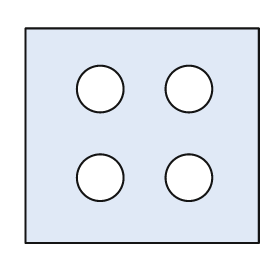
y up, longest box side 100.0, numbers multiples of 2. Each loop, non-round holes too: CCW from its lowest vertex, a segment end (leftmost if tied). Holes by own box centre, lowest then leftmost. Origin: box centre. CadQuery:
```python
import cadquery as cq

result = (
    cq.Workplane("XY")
    .moveTo(-50.0, -46.0)
    .lineTo(50.0, -46.0)
    .lineTo(50.0, 46.0)
    .lineTo(-50.0, 46.0)
    .close()
    .moveTo(-18.0, -18.0)
    .circle(10.0)
    .moveTo(20.0, -18.0)
    .circle(10.0)
    .moveTo(-18.0, 20.0)
    .circle(10.0)
    .moveTo(20.0, 20.0)
    .circle(10.0)
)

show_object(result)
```